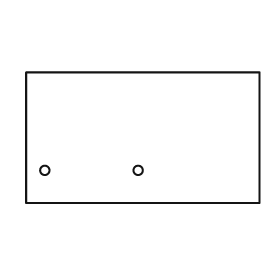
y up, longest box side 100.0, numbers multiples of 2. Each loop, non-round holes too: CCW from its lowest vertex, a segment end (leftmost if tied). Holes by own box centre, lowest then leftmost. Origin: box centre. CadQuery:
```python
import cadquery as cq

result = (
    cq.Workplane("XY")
    .moveTo(-50.0, -28.0)
    .lineTo(50.0, -28.0)
    .lineTo(50.0, 28.0)
    .lineTo(-50.0, 28.0)
    .close()
    .moveTo(-42.0, -14.0)
    .circle(2.0)
    .moveTo(-2.0, -14.0)
    .circle(2.0)
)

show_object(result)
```